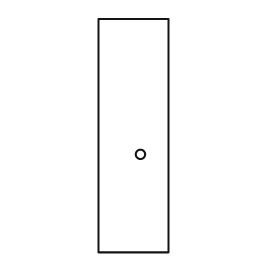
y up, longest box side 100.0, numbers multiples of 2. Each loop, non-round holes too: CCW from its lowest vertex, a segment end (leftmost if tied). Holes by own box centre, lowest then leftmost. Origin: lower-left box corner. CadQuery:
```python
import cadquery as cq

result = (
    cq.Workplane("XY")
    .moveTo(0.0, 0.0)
    .lineTo(30.0, 0.0)
    .lineTo(30.0, 100.0)
    .lineTo(0.0, 100.0)
    .close()
    .moveTo(18.0, 42.0)
    .circle(2.0)
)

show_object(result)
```